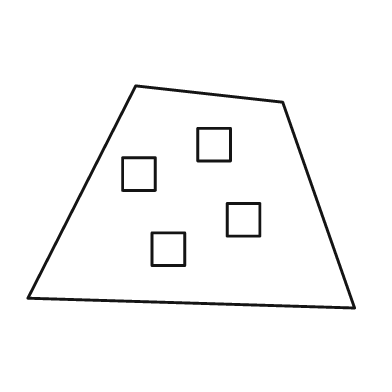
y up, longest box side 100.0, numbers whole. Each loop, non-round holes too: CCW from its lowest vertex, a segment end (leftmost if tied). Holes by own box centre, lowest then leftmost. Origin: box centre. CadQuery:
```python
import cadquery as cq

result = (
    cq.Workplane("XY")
    .moveTo(50.0, -34.0)
    .lineTo(28.0, 29.0)
    .lineTo(-17.0, 34.0)
    .lineTo(-50.0, -31.0)
    .close()
    .moveTo(-12.0, -21.0)
    .lineTo(-2.0, -21.0)
    .lineTo(-2.0, -11.0)
    .lineTo(-12.0, -11.0)
    .close()
    .moveTo(11.0, -12.0)
    .lineTo(21.0, -12.0)
    .lineTo(21.0, -2.0)
    .lineTo(11.0, -2.0)
    .close()
    .moveTo(-21.0, 2.0)
    .lineTo(-11.0, 2.0)
    .lineTo(-11.0, 12.0)
    .lineTo(-21.0, 12.0)
    .close()
    .moveTo(2.0, 11.0)
    .lineTo(12.0, 11.0)
    .lineTo(12.0, 21.0)
    .lineTo(2.0, 21.0)
    .close()
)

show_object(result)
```